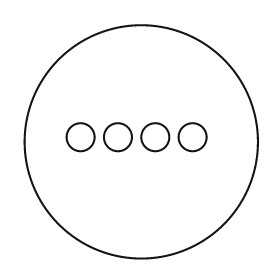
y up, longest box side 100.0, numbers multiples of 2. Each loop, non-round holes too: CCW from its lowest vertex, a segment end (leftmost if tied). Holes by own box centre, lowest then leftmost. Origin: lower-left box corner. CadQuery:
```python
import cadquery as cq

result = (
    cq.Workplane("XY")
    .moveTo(50.0, 50.0)
    .circle(50.0)
    .moveTo(24.0, 52.0)
    .circle(6.0)
    .moveTo(40.0, 52.0)
    .circle(6.0)
    .moveTo(56.0, 52.0)
    .circle(6.0)
    .moveTo(72.0, 52.0)
    .circle(6.0)
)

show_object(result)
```